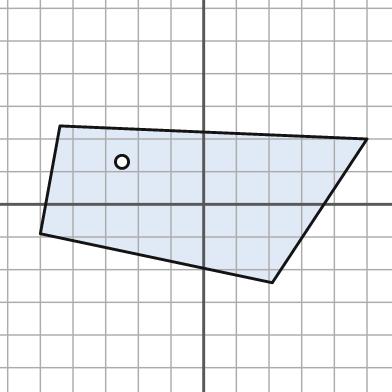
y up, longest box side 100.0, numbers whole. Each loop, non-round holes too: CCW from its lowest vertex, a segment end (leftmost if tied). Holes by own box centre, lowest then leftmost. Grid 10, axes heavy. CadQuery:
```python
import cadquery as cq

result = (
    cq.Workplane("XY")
    .moveTo(21.0, -24.0)
    .lineTo(50.0, 20.0)
    .lineTo(-44.0, 24.0)
    .lineTo(-50.0, -9.0)
    .close()
    .moveTo(-25.0, 13.0)
    .circle(2.0)
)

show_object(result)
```